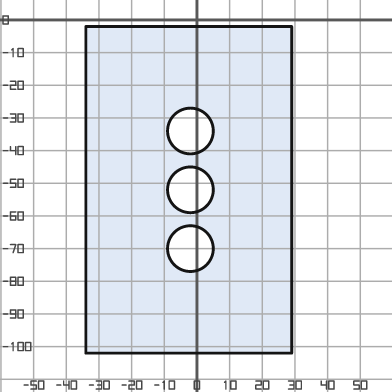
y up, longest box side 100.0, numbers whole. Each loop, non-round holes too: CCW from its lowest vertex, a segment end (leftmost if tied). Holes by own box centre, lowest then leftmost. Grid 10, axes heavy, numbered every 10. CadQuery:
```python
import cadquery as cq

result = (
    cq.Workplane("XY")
    .moveTo(-34.0, -102.0)
    .lineTo(29.0, -102.0)
    .lineTo(29.0, -2.0)
    .lineTo(-34.0, -2.0)
    .close()
    .moveTo(-2.0, -70.0)
    .circle(7.0)
    .moveTo(-2.0, -52.0)
    .circle(7.0)
    .moveTo(-2.0, -34.0)
    .circle(7.0)
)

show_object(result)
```